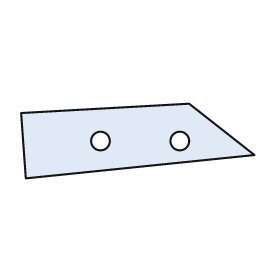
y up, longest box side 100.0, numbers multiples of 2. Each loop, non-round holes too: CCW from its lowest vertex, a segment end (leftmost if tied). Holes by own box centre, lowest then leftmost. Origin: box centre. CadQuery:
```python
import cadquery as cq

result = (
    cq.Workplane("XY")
    .moveTo(-48.0, -16.0)
    .lineTo(50.0, -6.0)
    .lineTo(22.0, 16.0)
    .lineTo(-50.0, 12.0)
    .close()
    .moveTo(-16.0, 0.0)
    .circle(4.0)
    .moveTo(18.0, 0.0)
    .circle(4.0)
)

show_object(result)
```